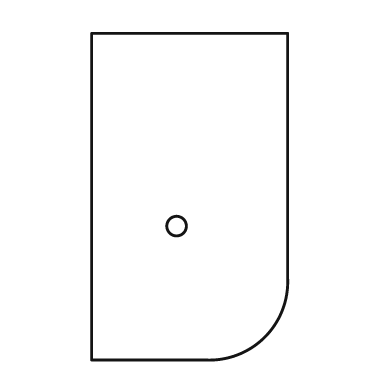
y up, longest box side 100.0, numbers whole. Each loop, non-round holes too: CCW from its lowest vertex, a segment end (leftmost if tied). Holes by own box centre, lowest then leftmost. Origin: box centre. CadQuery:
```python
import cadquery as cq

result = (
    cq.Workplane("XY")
    .moveTo(-30.0, -50.0)
    .lineTo(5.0, -50.0)
    .threePointArc((23.0, -43.0), (30.0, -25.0))
    .lineTo(30.0, 50.0)
    .lineTo(-30.0, 50.0)
    .close()
    .moveTo(-4.0, -9.0)
    .circle(3.0)
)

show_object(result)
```